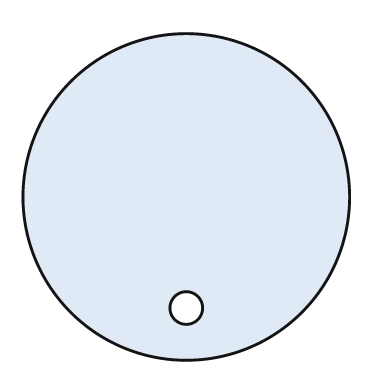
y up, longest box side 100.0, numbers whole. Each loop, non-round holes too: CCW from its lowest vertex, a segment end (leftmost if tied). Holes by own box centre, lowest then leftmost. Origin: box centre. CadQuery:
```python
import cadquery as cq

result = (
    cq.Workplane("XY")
    .moveTo(0.0, 0.0)
    .circle(50.0)
    .moveTo(0.0, -34.0)
    .circle(5.0)
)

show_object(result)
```